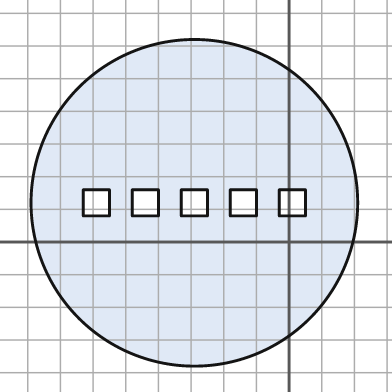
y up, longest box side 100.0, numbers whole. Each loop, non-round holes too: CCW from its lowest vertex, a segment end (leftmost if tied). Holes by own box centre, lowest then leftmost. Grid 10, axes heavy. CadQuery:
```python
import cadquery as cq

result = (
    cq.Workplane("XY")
    .moveTo(-29.0, 12.0)
    .circle(50.0)
    .moveTo(-63.0, 8.0)
    .lineTo(-55.0, 8.0)
    .lineTo(-55.0, 16.0)
    .lineTo(-63.0, 16.0)
    .close()
    .moveTo(-48.0, 8.0)
    .lineTo(-40.0, 8.0)
    .lineTo(-40.0, 16.0)
    .lineTo(-48.0, 16.0)
    .close()
    .moveTo(-33.0, 8.0)
    .lineTo(-25.0, 8.0)
    .lineTo(-25.0, 16.0)
    .lineTo(-33.0, 16.0)
    .close()
    .moveTo(-18.0, 8.0)
    .lineTo(-10.0, 8.0)
    .lineTo(-10.0, 16.0)
    .lineTo(-18.0, 16.0)
    .close()
    .moveTo(-3.0, 8.0)
    .lineTo(5.0, 8.0)
    .lineTo(5.0, 16.0)
    .lineTo(-3.0, 16.0)
    .close()
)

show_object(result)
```